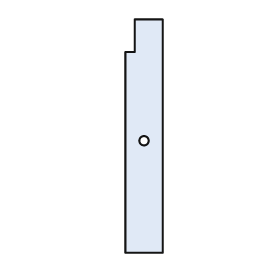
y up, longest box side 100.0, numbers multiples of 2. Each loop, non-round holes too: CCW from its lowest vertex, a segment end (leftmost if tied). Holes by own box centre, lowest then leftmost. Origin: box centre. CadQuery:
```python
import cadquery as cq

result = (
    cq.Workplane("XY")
    .moveTo(-8.0, -50.0)
    .lineTo(8.0, -50.0)
    .lineTo(8.0, 50.0)
    .lineTo(-4.0, 50.0)
    .lineTo(-4.0, 36.0)
    .lineTo(-8.0, 36.0)
    .close()
    .moveTo(0.0, -2.0)
    .circle(2.0)
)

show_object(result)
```